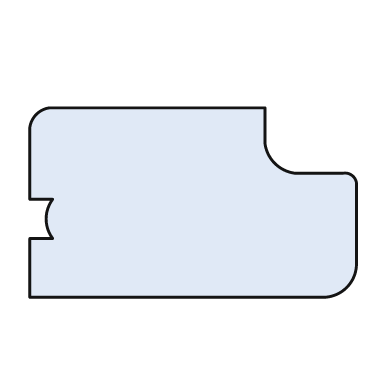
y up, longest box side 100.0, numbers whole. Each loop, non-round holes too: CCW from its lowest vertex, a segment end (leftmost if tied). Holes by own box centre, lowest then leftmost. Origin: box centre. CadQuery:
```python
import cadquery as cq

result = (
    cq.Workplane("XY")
    .moveTo(-50.0, -29.0)
    .lineTo(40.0, -29.0)
    .threePointArc((47.0, -26.0), (50.0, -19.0))
    .lineTo(50.0, 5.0)
    .threePointArc((49.0, 8.0), (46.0, 9.0))
    .lineTo(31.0, 9.0)
    .threePointArc((25.0, 12.0), (22.0, 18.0))
    .lineTo(22.0, 29.0)
    .lineTo(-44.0, 29.0)
    .threePointArc((-48.0, 27.0), (-50.0, 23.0))
    .lineTo(-50.0, 1.0)
    .lineTo(-43.0, 1.0)
    .threePointArc((-45.0, -5.0), (-43.0, -11.0))
    .lineTo(-50.0, -11.0)
    .close()
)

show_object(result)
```